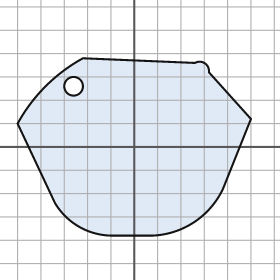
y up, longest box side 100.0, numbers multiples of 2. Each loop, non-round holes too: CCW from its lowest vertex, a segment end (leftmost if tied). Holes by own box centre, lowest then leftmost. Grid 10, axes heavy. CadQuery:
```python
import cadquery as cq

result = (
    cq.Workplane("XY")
    .moveTo(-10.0, -38.0)
    .lineTo(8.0, -38.0)
    .threePointArc((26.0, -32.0), (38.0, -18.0))
    .lineTo(50.0, 12.0)
    .lineTo(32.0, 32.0)
    .threePointArc((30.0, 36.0), (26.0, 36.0))
    .lineTo(-22.0, 38.0)
    .threePointArc((-38.0, 26.0), (-50.0, 10.0))
    .lineTo(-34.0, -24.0)
    .threePointArc((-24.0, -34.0), (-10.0, -38.0))
    .close()
    .moveTo(-26.0, 26.0)
    .circle(4.0)
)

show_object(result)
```